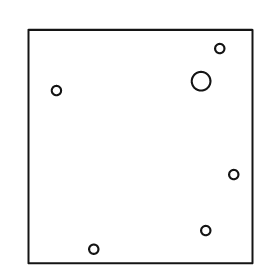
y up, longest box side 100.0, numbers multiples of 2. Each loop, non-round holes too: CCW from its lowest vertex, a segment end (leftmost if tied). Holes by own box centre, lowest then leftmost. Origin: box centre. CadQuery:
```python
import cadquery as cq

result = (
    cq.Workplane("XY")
    .moveTo(-48.0, -50.0)
    .lineTo(48.0, -50.0)
    .lineTo(48.0, 50.0)
    .lineTo(-48.0, 50.0)
    .close()
    .moveTo(-20.0, -44.0)
    .circle(2.0)
    .moveTo(28.0, -36.0)
    .circle(2.0)
    .moveTo(40.0, -12.0)
    .circle(2.0)
    .moveTo(-36.0, 24.0)
    .circle(2.0)
    .moveTo(26.0, 28.0)
    .circle(4.0)
    .moveTo(34.0, 42.0)
    .circle(2.0)
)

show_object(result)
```